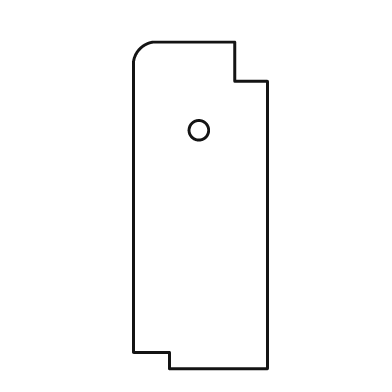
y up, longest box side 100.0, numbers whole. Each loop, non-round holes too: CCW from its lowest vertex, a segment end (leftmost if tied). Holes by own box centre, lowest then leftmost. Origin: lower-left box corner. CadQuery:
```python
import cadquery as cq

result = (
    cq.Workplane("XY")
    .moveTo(11.0, 0.0)
    .lineTo(41.0, 0.0)
    .lineTo(41.0, 88.0)
    .lineTo(31.0, 88.0)
    .lineTo(31.0, 100.0)
    .lineTo(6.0, 100.0)
    .threePointArc((2.0, 98.0), (0.0, 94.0))
    .lineTo(0.0, 5.0)
    .lineTo(11.0, 5.0)
    .close()
    .moveTo(20.0, 73.0)
    .circle(3.0)
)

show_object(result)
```